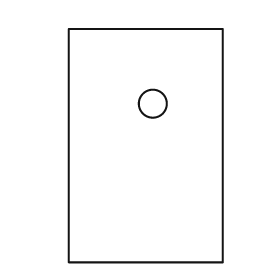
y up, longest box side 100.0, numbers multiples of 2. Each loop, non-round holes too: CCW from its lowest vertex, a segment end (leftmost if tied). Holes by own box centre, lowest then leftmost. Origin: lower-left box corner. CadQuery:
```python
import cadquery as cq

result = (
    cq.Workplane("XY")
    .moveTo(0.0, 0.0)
    .lineTo(66.0, 0.0)
    .lineTo(66.0, 100.0)
    .lineTo(0.0, 100.0)
    .close()
    .moveTo(36.0, 68.0)
    .circle(6.0)
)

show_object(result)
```